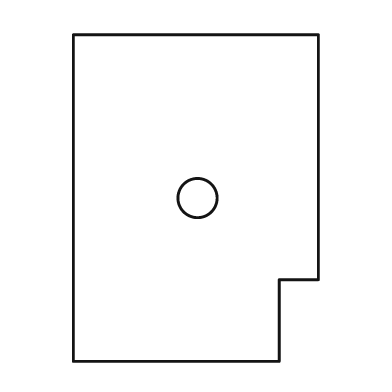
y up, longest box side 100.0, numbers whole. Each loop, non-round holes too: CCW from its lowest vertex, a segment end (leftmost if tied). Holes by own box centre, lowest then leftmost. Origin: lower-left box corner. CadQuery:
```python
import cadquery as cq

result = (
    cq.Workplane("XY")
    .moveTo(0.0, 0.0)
    .lineTo(63.0, 0.0)
    .lineTo(63.0, 25.0)
    .lineTo(75.0, 25.0)
    .lineTo(75.0, 100.0)
    .lineTo(0.0, 100.0)
    .close()
    .moveTo(38.0, 50.0)
    .circle(6.0)
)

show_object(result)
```